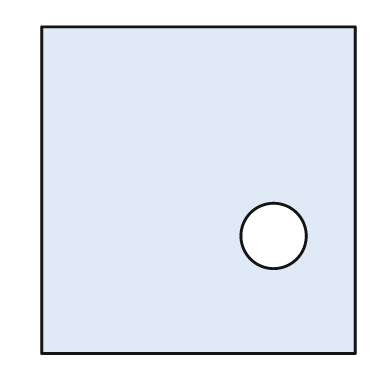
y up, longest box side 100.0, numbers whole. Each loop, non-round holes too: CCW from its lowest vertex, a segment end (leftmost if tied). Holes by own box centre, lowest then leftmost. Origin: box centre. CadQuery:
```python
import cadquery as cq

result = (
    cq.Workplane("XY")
    .moveTo(-48.0, -50.0)
    .lineTo(48.0, -50.0)
    .lineTo(48.0, 50.0)
    .lineTo(-48.0, 50.0)
    .close()
    .moveTo(23.0, -14.0)
    .circle(10.0)
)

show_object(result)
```